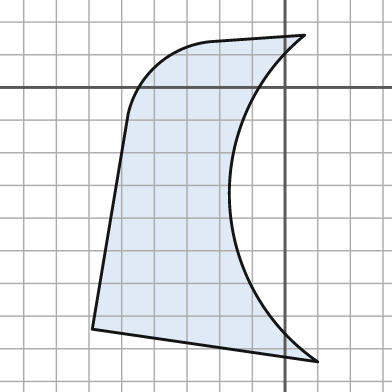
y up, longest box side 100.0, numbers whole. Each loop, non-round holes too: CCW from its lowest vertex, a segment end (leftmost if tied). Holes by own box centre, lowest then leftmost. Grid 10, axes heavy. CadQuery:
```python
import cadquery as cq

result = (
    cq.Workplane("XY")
    .moveTo(10.0, -84.0)
    .threePointArc((-17.0, -35.0), (6.0, 16.0))
    .lineTo(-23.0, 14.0)
    .threePointArc((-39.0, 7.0), (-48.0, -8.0))
    .lineTo(-59.0, -74.0)
    .close()
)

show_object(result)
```